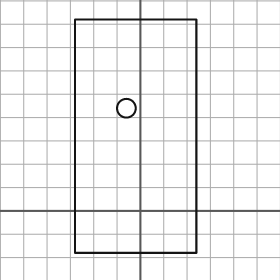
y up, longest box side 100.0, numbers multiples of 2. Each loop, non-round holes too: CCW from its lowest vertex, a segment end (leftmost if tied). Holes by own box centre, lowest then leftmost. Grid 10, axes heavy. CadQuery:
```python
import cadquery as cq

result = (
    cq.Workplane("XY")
    .moveTo(-28.0, -18.0)
    .lineTo(24.0, -18.0)
    .lineTo(24.0, 82.0)
    .lineTo(-28.0, 82.0)
    .close()
    .moveTo(-6.0, 44.0)
    .circle(4.0)
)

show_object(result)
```